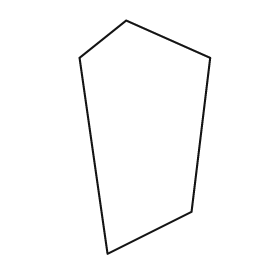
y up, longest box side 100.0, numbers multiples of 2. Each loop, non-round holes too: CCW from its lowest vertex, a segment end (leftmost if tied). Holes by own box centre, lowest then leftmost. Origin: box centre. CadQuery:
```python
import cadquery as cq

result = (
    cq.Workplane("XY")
    .moveTo(-16.0, -50.0)
    .lineTo(20.0, -32.0)
    .lineTo(28.0, 34.0)
    .lineTo(-8.0, 50.0)
    .lineTo(-28.0, 34.0)
    .close()
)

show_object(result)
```